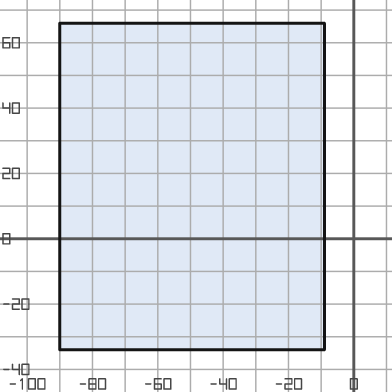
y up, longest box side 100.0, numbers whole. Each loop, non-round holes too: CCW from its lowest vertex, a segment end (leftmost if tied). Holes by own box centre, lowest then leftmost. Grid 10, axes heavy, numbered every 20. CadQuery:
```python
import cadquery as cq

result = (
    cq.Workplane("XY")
    .moveTo(-90.0, -34.0)
    .lineTo(-9.0, -34.0)
    .lineTo(-9.0, 66.0)
    .lineTo(-90.0, 66.0)
    .close()
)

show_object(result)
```